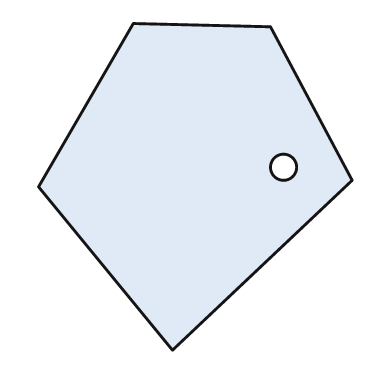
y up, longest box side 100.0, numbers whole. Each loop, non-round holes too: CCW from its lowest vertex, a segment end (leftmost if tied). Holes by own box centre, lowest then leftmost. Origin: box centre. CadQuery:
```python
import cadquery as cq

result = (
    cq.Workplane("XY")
    .moveTo(-7.0, -50.0)
    .lineTo(48.0, 2.0)
    .lineTo(23.0, 49.0)
    .lineTo(-19.0, 50.0)
    .lineTo(-48.0, 0.0)
    .close()
    .moveTo(27.0, 6.0)
    .circle(4.0)
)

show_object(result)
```